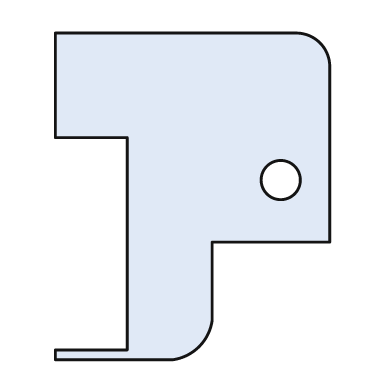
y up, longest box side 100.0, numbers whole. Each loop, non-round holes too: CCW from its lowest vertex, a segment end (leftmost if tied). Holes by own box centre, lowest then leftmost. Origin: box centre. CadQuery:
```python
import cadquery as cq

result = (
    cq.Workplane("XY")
    .moveTo(-42.0, -50.0)
    .lineTo(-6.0, -50.0)
    .threePointArc((2.0, -46.0), (6.0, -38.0))
    .lineTo(6.0, -14.0)
    .lineTo(42.0, -14.0)
    .lineTo(42.0, 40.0)
    .threePointArc((39.0, 47.0), (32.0, 50.0))
    .lineTo(-42.0, 50.0)
    .lineTo(-42.0, 18.0)
    .lineTo(-20.0, 18.0)
    .lineTo(-20.0, -47.0)
    .lineTo(-42.0, -47.0)
    .close()
    .moveTo(27.0, 5.0)
    .circle(6.0)
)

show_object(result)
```